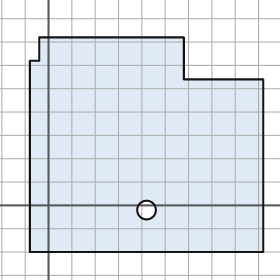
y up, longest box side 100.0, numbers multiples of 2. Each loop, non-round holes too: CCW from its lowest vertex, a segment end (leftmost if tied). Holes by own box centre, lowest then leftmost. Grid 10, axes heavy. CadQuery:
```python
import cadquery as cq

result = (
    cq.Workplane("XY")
    .moveTo(-8.0, -20.0)
    .lineTo(92.0, -20.0)
    .lineTo(92.0, 54.0)
    .lineTo(58.0, 54.0)
    .lineTo(58.0, 72.0)
    .lineTo(-4.0, 72.0)
    .lineTo(-4.0, 62.0)
    .lineTo(-8.0, 62.0)
    .close()
    .moveTo(42.0, -2.0)
    .circle(4.0)
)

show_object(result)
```